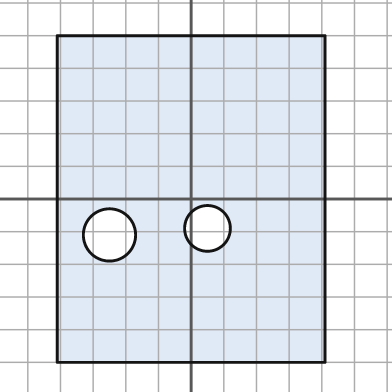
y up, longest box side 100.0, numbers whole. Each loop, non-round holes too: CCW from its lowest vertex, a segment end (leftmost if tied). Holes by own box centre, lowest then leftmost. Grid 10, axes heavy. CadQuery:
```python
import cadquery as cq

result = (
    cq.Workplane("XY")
    .moveTo(-41.0, -50.0)
    .lineTo(41.0, -50.0)
    .lineTo(41.0, 50.0)
    .lineTo(-41.0, 50.0)
    .close()
    .moveTo(-25.0, -11.0)
    .circle(8.0)
    .moveTo(5.0, -9.0)
    .circle(7.0)
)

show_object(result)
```